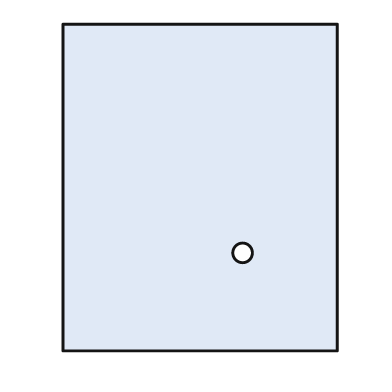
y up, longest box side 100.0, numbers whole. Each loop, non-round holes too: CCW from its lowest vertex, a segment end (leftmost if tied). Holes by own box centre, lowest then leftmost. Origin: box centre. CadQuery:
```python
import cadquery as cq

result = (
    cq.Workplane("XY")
    .moveTo(-42.0, -50.0)
    .lineTo(42.0, -50.0)
    .lineTo(42.0, 50.0)
    .lineTo(-42.0, 50.0)
    .close()
    .moveTo(13.0, -20.0)
    .circle(3.0)
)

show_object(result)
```